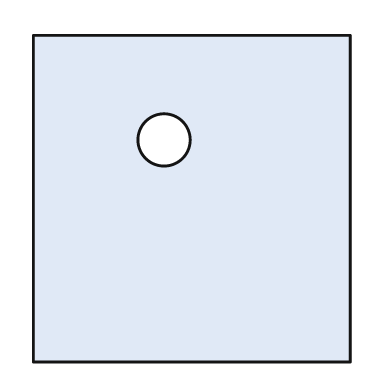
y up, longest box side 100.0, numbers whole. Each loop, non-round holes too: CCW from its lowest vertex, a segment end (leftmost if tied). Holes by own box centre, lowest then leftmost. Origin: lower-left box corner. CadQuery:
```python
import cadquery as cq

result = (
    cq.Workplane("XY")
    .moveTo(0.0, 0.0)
    .lineTo(97.0, 0.0)
    .lineTo(97.0, 100.0)
    .lineTo(0.0, 100.0)
    .close()
    .moveTo(40.0, 68.0)
    .circle(8.0)
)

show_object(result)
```